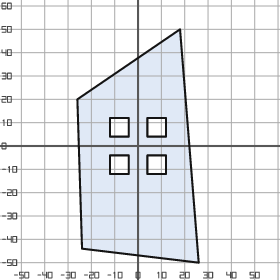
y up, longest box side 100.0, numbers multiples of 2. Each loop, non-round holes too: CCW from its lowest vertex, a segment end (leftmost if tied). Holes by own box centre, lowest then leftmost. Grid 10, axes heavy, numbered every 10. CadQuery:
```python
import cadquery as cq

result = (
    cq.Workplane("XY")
    .moveTo(26.0, -50.0)
    .lineTo(18.0, 50.0)
    .lineTo(-26.0, 20.0)
    .lineTo(-24.0, -44.0)
    .close()
    .moveTo(-12.0, -12.0)
    .lineTo(-4.0, -12.0)
    .lineTo(-4.0, -4.0)
    .lineTo(-12.0, -4.0)
    .close()
    .moveTo(4.0, -12.0)
    .lineTo(12.0, -12.0)
    .lineTo(12.0, -4.0)
    .lineTo(4.0, -4.0)
    .close()
    .moveTo(-12.0, 4.0)
    .lineTo(-4.0, 4.0)
    .lineTo(-4.0, 12.0)
    .lineTo(-12.0, 12.0)
    .close()
    .moveTo(4.0, 4.0)
    .lineTo(12.0, 4.0)
    .lineTo(12.0, 12.0)
    .lineTo(4.0, 12.0)
    .close()
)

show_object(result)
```